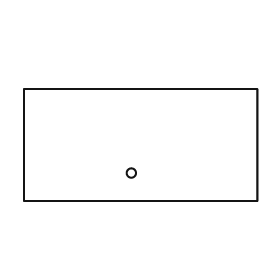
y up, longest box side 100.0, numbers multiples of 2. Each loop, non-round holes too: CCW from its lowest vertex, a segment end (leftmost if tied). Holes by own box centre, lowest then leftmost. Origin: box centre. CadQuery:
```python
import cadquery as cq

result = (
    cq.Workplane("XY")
    .moveTo(-50.0, -24.0)
    .lineTo(50.0, -24.0)
    .lineTo(50.0, 24.0)
    .lineTo(-50.0, 24.0)
    .close()
    .moveTo(-4.0, -12.0)
    .circle(2.0)
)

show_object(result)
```